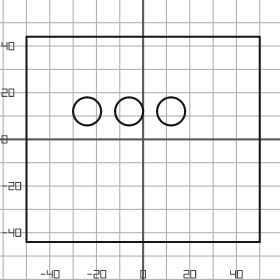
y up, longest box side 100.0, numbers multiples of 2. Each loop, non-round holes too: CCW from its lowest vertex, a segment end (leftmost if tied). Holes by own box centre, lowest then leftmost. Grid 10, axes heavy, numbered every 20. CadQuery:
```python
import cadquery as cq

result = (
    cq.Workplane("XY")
    .moveTo(-50.0, -44.0)
    .lineTo(50.0, -44.0)
    .lineTo(50.0, 44.0)
    .lineTo(-50.0, 44.0)
    .close()
    .moveTo(-24.0, 12.0)
    .circle(6.0)
    .moveTo(-6.0, 12.0)
    .circle(6.0)
    .moveTo(12.0, 12.0)
    .circle(6.0)
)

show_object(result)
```